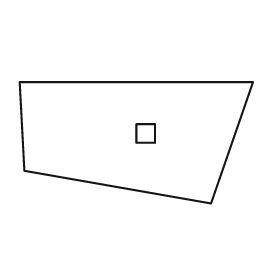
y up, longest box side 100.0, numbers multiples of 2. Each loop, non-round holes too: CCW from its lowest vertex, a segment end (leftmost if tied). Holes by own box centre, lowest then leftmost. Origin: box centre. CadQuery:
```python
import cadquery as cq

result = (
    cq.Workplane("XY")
    .moveTo(32.0, -26.0)
    .lineTo(50.0, 26.0)
    .lineTo(-50.0, 26.0)
    .lineTo(-48.0, -12.0)
    .close()
    .moveTo(0.0, 0.0)
    .lineTo(8.0, 0.0)
    .lineTo(8.0, 8.0)
    .lineTo(0.0, 8.0)
    .close()
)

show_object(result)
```